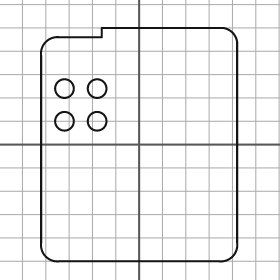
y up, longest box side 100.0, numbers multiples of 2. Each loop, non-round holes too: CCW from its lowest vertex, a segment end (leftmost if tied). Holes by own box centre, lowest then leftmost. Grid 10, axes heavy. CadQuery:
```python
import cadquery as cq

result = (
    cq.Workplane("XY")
    .moveTo(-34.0, -50.0)
    .lineTo(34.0, -50.0)
    .threePointArc((40.0, -48.0), (42.0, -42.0))
    .lineTo(42.0, 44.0)
    .threePointArc((40.0, 48.0), (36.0, 50.0))
    .lineTo(-16.0, 50.0)
    .lineTo(-16.0, 46.0)
    .lineTo(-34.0, 46.0)
    .threePointArc((-40.0, 44.0), (-42.0, 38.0))
    .lineTo(-42.0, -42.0)
    .threePointArc((-40.0, -48.0), (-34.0, -50.0))
    .close()
    .moveTo(-32.0, 10.0)
    .circle(4.0)
    .moveTo(-18.0, 10.0)
    .circle(4.0)
    .moveTo(-32.0, 24.0)
    .circle(4.0)
    .moveTo(-18.0, 24.0)
    .circle(4.0)
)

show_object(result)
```